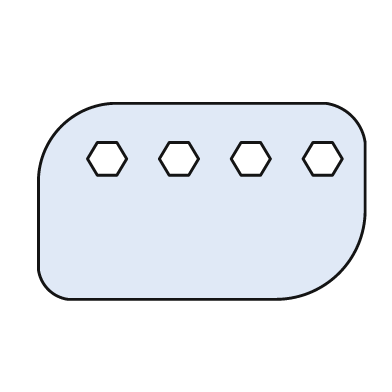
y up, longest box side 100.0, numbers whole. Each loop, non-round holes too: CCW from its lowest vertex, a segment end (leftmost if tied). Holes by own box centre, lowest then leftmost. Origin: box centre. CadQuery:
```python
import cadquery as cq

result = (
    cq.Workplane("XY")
    .moveTo(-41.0, -30.0)
    .lineTo(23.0, -30.0)
    .threePointArc((42.0, -22.0), (50.0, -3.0))
    .lineTo(50.0, 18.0)
    .threePointArc((46.0, 26.0), (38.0, 30.0))
    .lineTo(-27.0, 30.0)
    .threePointArc((-43.0, 23.0), (-50.0, 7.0))
    .lineTo(-50.0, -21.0)
    .threePointArc((-47.0, -27.0), (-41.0, -30.0))
    .close()
    .moveTo(-32.0, 8.0)
    .lineTo(-26.0, 8.0)
    .lineTo(-23.0, 13.0)
    .lineTo(-26.0, 18.0)
    .lineTo(-32.0, 18.0)
    .lineTo(-35.0, 13.0)
    .close()
    .moveTo(-10.0, 8.0)
    .lineTo(-4.0, 8.0)
    .lineTo(-1.0, 13.0)
    .lineTo(-4.0, 18.0)
    .lineTo(-10.0, 18.0)
    .lineTo(-13.0, 13.0)
    .close()
    .moveTo(12.0, 8.0)
    .lineTo(18.0, 8.0)
    .lineTo(21.0, 13.0)
    .lineTo(18.0, 18.0)
    .lineTo(12.0, 18.0)
    .lineTo(9.0, 13.0)
    .close()
    .moveTo(34.0, 8.0)
    .lineTo(40.0, 8.0)
    .lineTo(43.0, 13.0)
    .lineTo(40.0, 18.0)
    .lineTo(34.0, 18.0)
    .lineTo(31.0, 13.0)
    .close()
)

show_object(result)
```